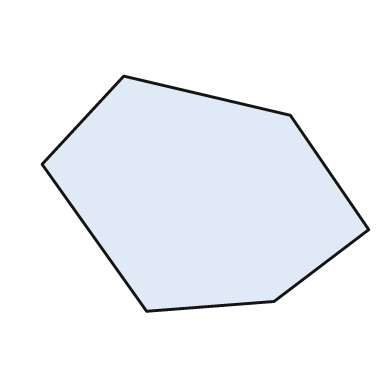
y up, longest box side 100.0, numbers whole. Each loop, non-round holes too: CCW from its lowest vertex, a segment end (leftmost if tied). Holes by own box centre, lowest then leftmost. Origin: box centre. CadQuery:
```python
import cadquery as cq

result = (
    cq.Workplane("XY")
    .moveTo(-18.0, -36.0)
    .lineTo(21.0, -33.0)
    .lineTo(50.0, -11.0)
    .lineTo(26.0, 24.0)
    .lineTo(-25.0, 36.0)
    .lineTo(-50.0, 9.0)
    .close()
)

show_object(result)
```